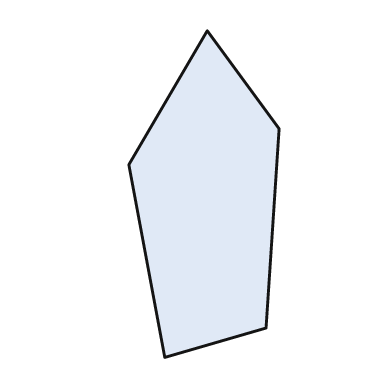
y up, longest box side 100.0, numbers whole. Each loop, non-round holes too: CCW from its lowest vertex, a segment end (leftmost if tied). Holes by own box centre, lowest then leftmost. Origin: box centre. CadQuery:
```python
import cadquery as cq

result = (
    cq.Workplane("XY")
    .moveTo(-12.0, -50.0)
    .lineTo(19.0, -41.0)
    .lineTo(23.0, 20.0)
    .lineTo(1.0, 50.0)
    .lineTo(-23.0, 9.0)
    .close()
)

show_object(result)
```